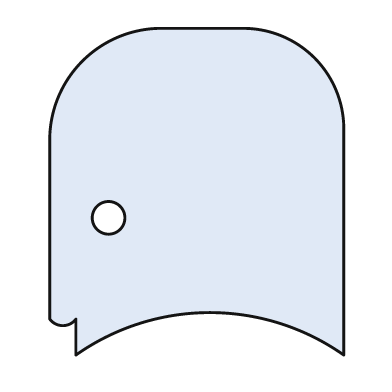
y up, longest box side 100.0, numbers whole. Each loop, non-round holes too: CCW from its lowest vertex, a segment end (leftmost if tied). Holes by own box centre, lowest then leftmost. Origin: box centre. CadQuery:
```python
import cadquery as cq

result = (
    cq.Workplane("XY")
    .moveTo(-37.0, -50.0)
    .threePointArc((4.0, -37.0), (45.0, -50.0))
    .lineTo(45.0, 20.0)
    .threePointArc((36.0, 41.0), (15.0, 50.0))
    .lineTo(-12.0, 50.0)
    .threePointArc((-35.0, 40.0), (-45.0, 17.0))
    .lineTo(-45.0, -39.0)
    .threePointArc((-41.0, -41.0), (-37.0, -39.0))
    .close()
    .moveTo(-27.0, -8.0)
    .circle(5.0)
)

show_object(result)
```